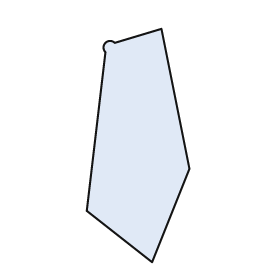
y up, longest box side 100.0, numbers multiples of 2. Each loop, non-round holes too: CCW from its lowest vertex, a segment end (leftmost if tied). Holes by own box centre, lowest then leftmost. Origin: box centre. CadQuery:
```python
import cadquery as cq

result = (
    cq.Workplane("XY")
    .moveTo(6.0, -50.0)
    .lineTo(22.0, -10.0)
    .lineTo(10.0, 50.0)
    .lineTo(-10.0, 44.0)
    .threePointArc((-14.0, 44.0), (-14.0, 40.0))
    .lineTo(-22.0, -28.0)
    .close()
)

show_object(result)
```